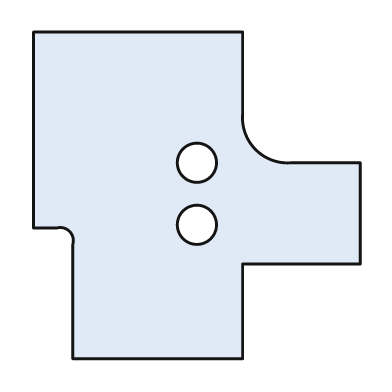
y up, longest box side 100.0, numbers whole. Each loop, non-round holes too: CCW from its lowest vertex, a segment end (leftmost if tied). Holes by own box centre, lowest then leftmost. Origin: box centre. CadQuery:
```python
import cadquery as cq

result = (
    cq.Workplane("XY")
    .moveTo(-38.0, -50.0)
    .lineTo(14.0, -50.0)
    .lineTo(14.0, -21.0)
    .lineTo(50.0, -21.0)
    .lineTo(50.0, 10.0)
    .lineTo(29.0, 10.0)
    .threePointArc((18.0, 14.0), (14.0, 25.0))
    .lineTo(14.0, 50.0)
    .lineTo(-50.0, 50.0)
    .lineTo(-50.0, -10.0)
    .lineTo(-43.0, -10.0)
    .threePointArc((-39.0, -11.0), (-38.0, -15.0))
    .close()
    .moveTo(0.0, -9.0)
    .circle(6.0)
    .moveTo(0.0, 10.0)
    .circle(6.0)
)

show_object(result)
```